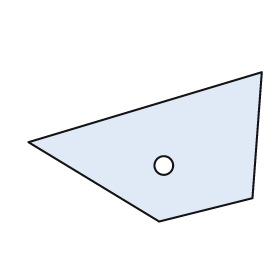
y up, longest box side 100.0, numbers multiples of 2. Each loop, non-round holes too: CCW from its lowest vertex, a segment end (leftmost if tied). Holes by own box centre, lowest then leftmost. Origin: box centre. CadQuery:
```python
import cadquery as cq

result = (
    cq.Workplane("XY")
    .moveTo(6.0, -32.0)
    .lineTo(46.0, -22.0)
    .lineTo(50.0, 32.0)
    .lineTo(-50.0, 2.0)
    .close()
    .moveTo(8.0, -8.0)
    .circle(4.0)
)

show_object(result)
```